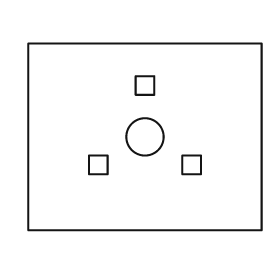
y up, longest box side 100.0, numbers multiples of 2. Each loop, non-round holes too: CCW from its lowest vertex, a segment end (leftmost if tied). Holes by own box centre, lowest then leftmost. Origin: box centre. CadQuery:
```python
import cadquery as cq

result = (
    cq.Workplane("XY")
    .moveTo(-50.0, -40.0)
    .lineTo(50.0, -40.0)
    .lineTo(50.0, 40.0)
    .lineTo(-50.0, 40.0)
    .close()
    .moveTo(-24.0, -16.0)
    .lineTo(-16.0, -16.0)
    .lineTo(-16.0, -8.0)
    .lineTo(-24.0, -8.0)
    .close()
    .moveTo(16.0, -16.0)
    .lineTo(24.0, -16.0)
    .lineTo(24.0, -8.0)
    .lineTo(16.0, -8.0)
    .close()
    .moveTo(0.0, 0.0)
    .circle(8.0)
    .moveTo(-4.0, 18.0)
    .lineTo(4.0, 18.0)
    .lineTo(4.0, 26.0)
    .lineTo(-4.0, 26.0)
    .close()
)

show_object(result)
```